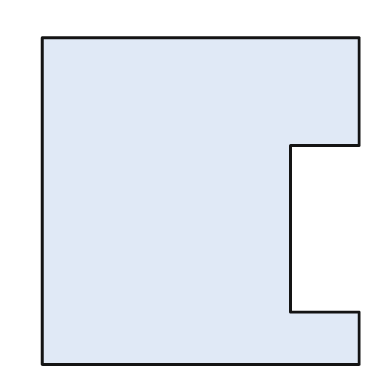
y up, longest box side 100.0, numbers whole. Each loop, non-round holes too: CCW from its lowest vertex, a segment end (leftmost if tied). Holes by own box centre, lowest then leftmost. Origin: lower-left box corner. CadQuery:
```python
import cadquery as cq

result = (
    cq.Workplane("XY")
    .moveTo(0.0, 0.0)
    .lineTo(97.0, 0.0)
    .lineTo(97.0, 16.0)
    .lineTo(76.0, 16.0)
    .lineTo(76.0, 67.0)
    .lineTo(97.0, 67.0)
    .lineTo(97.0, 100.0)
    .lineTo(0.0, 100.0)
    .close()
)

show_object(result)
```